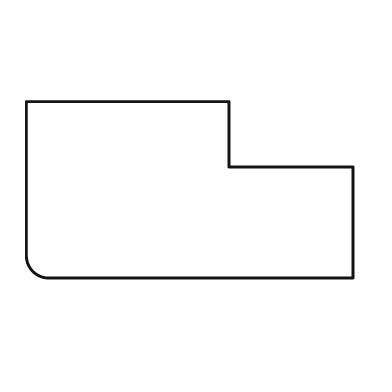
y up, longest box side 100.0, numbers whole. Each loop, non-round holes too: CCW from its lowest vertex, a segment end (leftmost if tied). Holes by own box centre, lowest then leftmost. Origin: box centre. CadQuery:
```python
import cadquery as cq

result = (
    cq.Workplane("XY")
    .moveTo(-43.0, -27.0)
    .lineTo(50.0, -27.0)
    .lineTo(50.0, 7.0)
    .lineTo(12.0, 7.0)
    .lineTo(12.0, 27.0)
    .lineTo(-50.0, 27.0)
    .lineTo(-50.0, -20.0)
    .threePointArc((-48.0, -25.0), (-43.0, -27.0))
    .close()
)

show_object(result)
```